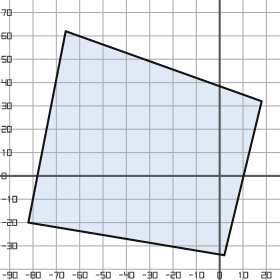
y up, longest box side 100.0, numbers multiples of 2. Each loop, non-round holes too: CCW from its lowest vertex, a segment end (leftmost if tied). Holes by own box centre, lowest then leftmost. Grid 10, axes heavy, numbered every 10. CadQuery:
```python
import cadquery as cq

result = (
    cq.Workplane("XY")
    .moveTo(2.0, -34.0)
    .lineTo(18.0, 32.0)
    .lineTo(-66.0, 62.0)
    .lineTo(-82.0, -20.0)
    .close()
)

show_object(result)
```